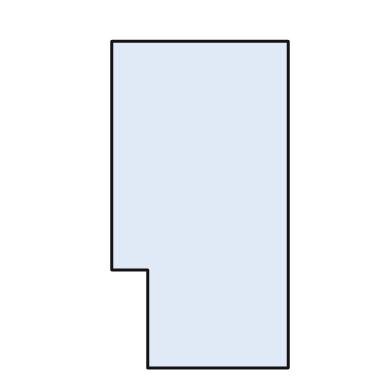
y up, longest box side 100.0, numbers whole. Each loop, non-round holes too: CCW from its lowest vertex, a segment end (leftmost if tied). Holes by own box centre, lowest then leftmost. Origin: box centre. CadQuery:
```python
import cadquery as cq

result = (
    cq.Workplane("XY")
    .moveTo(-16.0, -50.0)
    .lineTo(27.0, -50.0)
    .lineTo(27.0, 50.0)
    .lineTo(-27.0, 50.0)
    .lineTo(-27.0, -20.0)
    .lineTo(-16.0, -20.0)
    .close()
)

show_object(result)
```